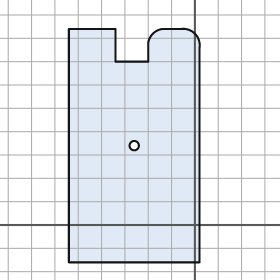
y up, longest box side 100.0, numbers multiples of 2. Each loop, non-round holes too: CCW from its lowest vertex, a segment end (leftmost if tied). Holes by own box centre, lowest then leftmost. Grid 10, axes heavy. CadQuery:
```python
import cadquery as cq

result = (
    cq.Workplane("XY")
    .moveTo(-54.0, -16.0)
    .lineTo(2.0, -16.0)
    .lineTo(2.0, 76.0)
    .threePointArc((0.0, 82.0), (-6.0, 84.0))
    .lineTo(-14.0, 84.0)
    .threePointArc((-18.0, 82.0), (-20.0, 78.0))
    .lineTo(-20.0, 70.0)
    .lineTo(-34.0, 70.0)
    .lineTo(-34.0, 84.0)
    .lineTo(-54.0, 84.0)
    .close()
    .moveTo(-26.0, 34.0)
    .circle(2.0)
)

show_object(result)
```